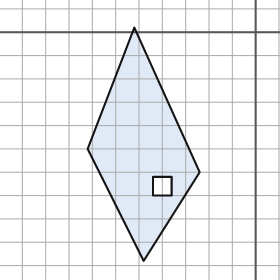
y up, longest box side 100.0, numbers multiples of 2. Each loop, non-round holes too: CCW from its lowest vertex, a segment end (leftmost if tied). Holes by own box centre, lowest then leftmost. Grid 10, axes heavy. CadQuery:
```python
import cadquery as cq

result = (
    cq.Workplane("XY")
    .moveTo(-48.0, -98.0)
    .lineTo(-24.0, -60.0)
    .lineTo(-52.0, 2.0)
    .lineTo(-72.0, -50.0)
    .close()
    .moveTo(-44.0, -70.0)
    .lineTo(-36.0, -70.0)
    .lineTo(-36.0, -62.0)
    .lineTo(-44.0, -62.0)
    .close()
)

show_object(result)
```